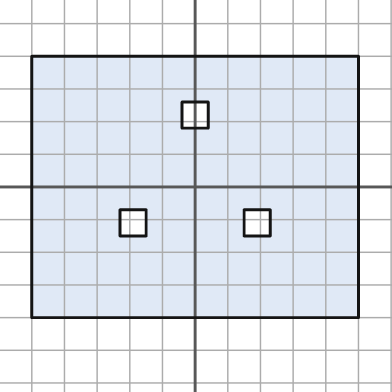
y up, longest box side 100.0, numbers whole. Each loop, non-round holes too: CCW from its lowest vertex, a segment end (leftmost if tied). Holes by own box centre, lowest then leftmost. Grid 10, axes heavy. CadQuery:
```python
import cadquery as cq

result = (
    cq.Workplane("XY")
    .moveTo(-50.0, -40.0)
    .lineTo(50.0, -40.0)
    .lineTo(50.0, 40.0)
    .lineTo(-50.0, 40.0)
    .close()
    .moveTo(-23.0, -15.0)
    .lineTo(-15.0, -15.0)
    .lineTo(-15.0, -7.0)
    .lineTo(-23.0, -7.0)
    .close()
    .moveTo(15.0, -15.0)
    .lineTo(23.0, -15.0)
    .lineTo(23.0, -7.0)
    .lineTo(15.0, -7.0)
    .close()
    .moveTo(-4.0, 18.0)
    .lineTo(4.0, 18.0)
    .lineTo(4.0, 26.0)
    .lineTo(-4.0, 26.0)
    .close()
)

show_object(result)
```